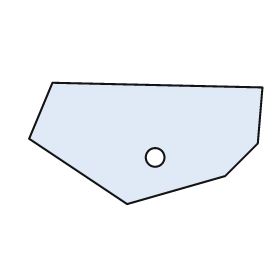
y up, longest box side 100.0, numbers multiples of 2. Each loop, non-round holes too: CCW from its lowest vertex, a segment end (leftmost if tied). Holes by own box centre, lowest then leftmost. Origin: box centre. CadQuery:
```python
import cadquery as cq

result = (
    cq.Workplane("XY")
    .moveTo(-8.0, -26.0)
    .lineTo(34.0, -14.0)
    .lineTo(48.0, 0.0)
    .lineTo(50.0, 24.0)
    .lineTo(-40.0, 26.0)
    .lineTo(-50.0, 2.0)
    .close()
    .moveTo(4.0, -6.0)
    .circle(4.0)
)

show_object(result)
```